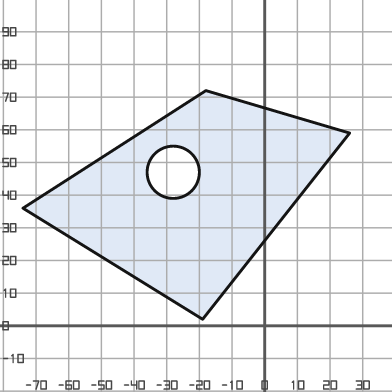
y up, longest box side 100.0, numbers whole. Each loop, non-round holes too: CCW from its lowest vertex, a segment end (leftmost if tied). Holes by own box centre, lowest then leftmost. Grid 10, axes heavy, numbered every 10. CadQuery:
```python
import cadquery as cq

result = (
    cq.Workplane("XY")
    .moveTo(-19.0, 2.0)
    .lineTo(26.0, 59.0)
    .lineTo(-18.0, 72.0)
    .lineTo(-74.0, 36.0)
    .close()
    .moveTo(-28.0, 47.0)
    .circle(8.0)
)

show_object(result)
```